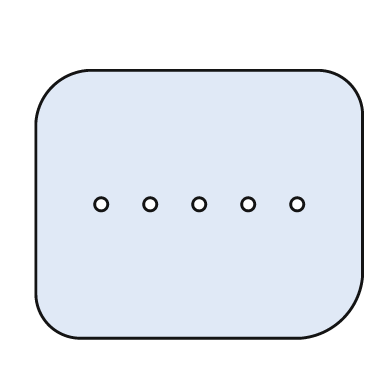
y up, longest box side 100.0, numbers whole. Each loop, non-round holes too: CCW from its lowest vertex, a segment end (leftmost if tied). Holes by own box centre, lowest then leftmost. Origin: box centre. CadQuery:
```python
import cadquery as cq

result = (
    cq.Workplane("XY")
    .moveTo(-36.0, -41.0)
    .lineTo(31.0, -41.0)
    .threePointArc((44.0, -35.0), (50.0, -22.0))
    .lineTo(50.0, 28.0)
    .threePointArc((46.0, 37.0), (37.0, 41.0))
    .lineTo(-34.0, 41.0)
    .threePointArc((-45.0, 36.0), (-50.0, 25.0))
    .lineTo(-50.0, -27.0)
    .threePointArc((-46.0, -37.0), (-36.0, -41.0))
    .close()
    .moveTo(-30.0, 0.0)
    .circle(2.0)
    .moveTo(-15.0, 0.0)
    .circle(2.0)
    .moveTo(0.0, 0.0)
    .circle(2.0)
    .moveTo(15.0, 0.0)
    .circle(2.0)
    .moveTo(30.0, 0.0)
    .circle(2.0)
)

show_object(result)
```